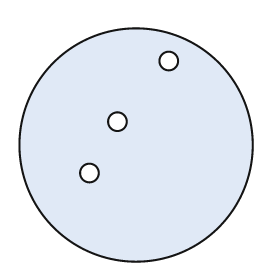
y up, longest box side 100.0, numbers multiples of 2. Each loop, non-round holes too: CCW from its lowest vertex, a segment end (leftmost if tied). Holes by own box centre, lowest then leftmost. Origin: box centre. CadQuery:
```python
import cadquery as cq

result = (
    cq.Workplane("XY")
    .moveTo(0.0, 0.0)
    .circle(50.0)
    .moveTo(-20.0, -12.0)
    .circle(4.0)
    .moveTo(-8.0, 10.0)
    .circle(4.0)
    .moveTo(14.0, 36.0)
    .circle(4.0)
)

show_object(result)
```